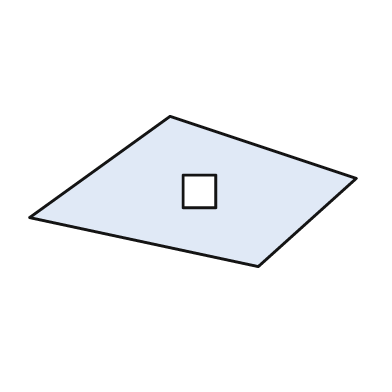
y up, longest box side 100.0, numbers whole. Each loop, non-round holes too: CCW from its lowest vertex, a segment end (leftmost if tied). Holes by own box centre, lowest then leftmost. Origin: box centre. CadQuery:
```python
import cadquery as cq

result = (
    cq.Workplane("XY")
    .moveTo(20.0, -23.0)
    .lineTo(50.0, 4.0)
    .lineTo(-7.0, 23.0)
    .lineTo(-50.0, -8.0)
    .close()
    .moveTo(-3.0, -5.0)
    .lineTo(7.0, -5.0)
    .lineTo(7.0, 5.0)
    .lineTo(-3.0, 5.0)
    .close()
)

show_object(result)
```